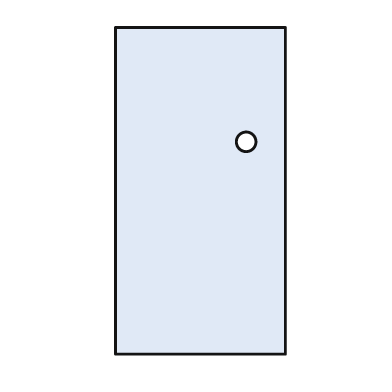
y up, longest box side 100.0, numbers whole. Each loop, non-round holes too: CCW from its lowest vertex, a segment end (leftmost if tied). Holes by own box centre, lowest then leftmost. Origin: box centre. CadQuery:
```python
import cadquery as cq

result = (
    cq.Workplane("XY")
    .moveTo(-26.0, -50.0)
    .lineTo(26.0, -50.0)
    .lineTo(26.0, 50.0)
    .lineTo(-26.0, 50.0)
    .close()
    .moveTo(14.0, 15.0)
    .circle(3.0)
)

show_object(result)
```